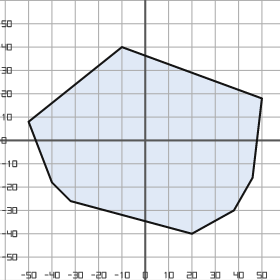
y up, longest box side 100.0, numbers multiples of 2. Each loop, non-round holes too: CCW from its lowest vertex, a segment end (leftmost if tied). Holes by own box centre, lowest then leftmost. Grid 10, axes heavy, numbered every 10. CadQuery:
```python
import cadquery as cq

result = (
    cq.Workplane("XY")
    .moveTo(20.0, -40.0)
    .lineTo(38.0, -30.0)
    .lineTo(46.0, -16.0)
    .lineTo(50.0, 18.0)
    .lineTo(-10.0, 40.0)
    .lineTo(-50.0, 8.0)
    .lineTo(-40.0, -18.0)
    .lineTo(-32.0, -26.0)
    .close()
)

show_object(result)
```